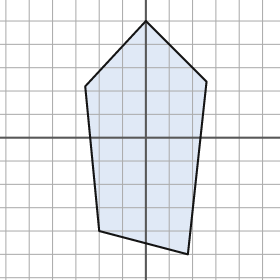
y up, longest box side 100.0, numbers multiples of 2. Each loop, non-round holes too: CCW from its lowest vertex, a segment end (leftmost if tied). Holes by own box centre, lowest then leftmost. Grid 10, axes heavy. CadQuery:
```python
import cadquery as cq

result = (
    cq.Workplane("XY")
    .moveTo(18.0, -50.0)
    .lineTo(26.0, 24.0)
    .lineTo(0.0, 50.0)
    .lineTo(-26.0, 22.0)
    .lineTo(-20.0, -40.0)
    .close()
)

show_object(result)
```